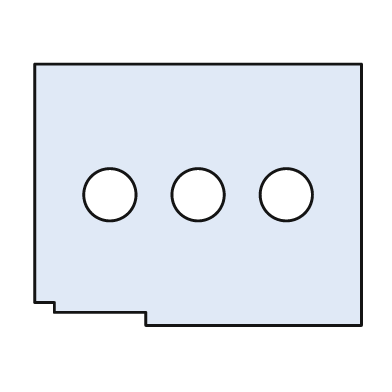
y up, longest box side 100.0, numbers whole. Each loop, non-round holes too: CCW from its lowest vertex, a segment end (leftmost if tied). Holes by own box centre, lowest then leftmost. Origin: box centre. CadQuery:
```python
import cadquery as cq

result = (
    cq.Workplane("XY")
    .moveTo(-16.0, -40.0)
    .lineTo(50.0, -40.0)
    .lineTo(50.0, 40.0)
    .lineTo(-50.0, 40.0)
    .lineTo(-50.0, -33.0)
    .lineTo(-44.0, -33.0)
    .lineTo(-44.0, -36.0)
    .lineTo(-16.0, -36.0)
    .close()
    .moveTo(-27.0, 0.0)
    .circle(8.0)
    .moveTo(0.0, 0.0)
    .circle(8.0)
    .moveTo(27.0, 0.0)
    .circle(8.0)
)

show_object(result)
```